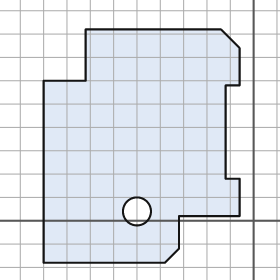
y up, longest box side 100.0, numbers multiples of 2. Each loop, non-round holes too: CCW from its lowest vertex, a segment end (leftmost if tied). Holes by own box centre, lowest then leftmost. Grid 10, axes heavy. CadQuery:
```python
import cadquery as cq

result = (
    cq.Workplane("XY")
    .moveTo(-90.0, -18.0)
    .lineTo(-38.0, -18.0)
    .lineTo(-32.0, -12.0)
    .lineTo(-32.0, 2.0)
    .lineTo(-6.0, 2.0)
    .lineTo(-6.0, 18.0)
    .lineTo(-12.0, 18.0)
    .lineTo(-12.0, 58.0)
    .lineTo(-6.0, 58.0)
    .lineTo(-6.0, 74.0)
    .lineTo(-14.0, 82.0)
    .lineTo(-72.0, 82.0)
    .lineTo(-72.0, 60.0)
    .lineTo(-90.0, 60.0)
    .close()
    .moveTo(-50.0, 4.0)
    .circle(6.0)
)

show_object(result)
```